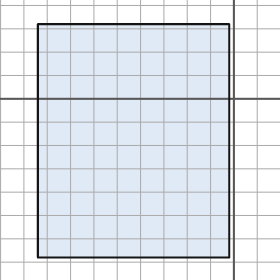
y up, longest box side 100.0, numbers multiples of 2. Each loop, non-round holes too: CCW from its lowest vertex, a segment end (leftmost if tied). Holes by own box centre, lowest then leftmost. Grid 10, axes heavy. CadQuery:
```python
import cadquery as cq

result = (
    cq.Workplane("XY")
    .moveTo(-84.0, -68.0)
    .lineTo(-2.0, -68.0)
    .lineTo(-2.0, 32.0)
    .lineTo(-84.0, 32.0)
    .close()
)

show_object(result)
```